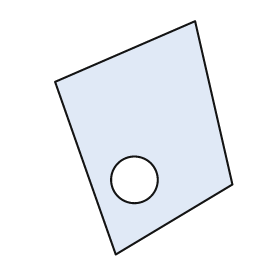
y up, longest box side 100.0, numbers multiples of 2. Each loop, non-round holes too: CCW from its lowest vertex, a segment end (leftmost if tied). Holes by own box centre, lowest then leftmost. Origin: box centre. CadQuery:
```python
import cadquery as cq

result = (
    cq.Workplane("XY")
    .moveTo(-12.0, -50.0)
    .lineTo(38.0, -20.0)
    .lineTo(22.0, 50.0)
    .lineTo(-38.0, 24.0)
    .close()
    .moveTo(-4.0, -18.0)
    .circle(10.0)
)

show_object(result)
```